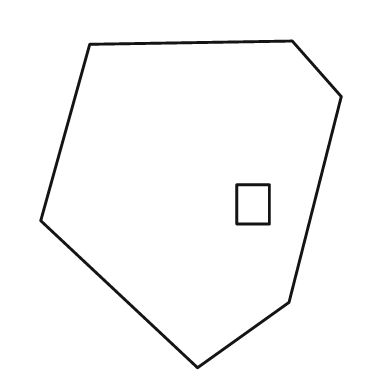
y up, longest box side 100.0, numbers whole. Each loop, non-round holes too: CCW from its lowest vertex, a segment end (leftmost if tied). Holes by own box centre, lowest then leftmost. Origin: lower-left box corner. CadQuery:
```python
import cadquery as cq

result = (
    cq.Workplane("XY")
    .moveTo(48.0, 0.0)
    .lineTo(76.0, 20.0)
    .lineTo(92.0, 83.0)
    .lineTo(77.0, 100.0)
    .lineTo(15.0, 99.0)
    .lineTo(0.0, 45.0)
    .close()
    .moveTo(60.0, 44.0)
    .lineTo(70.0, 44.0)
    .lineTo(70.0, 56.0)
    .lineTo(60.0, 56.0)
    .close()
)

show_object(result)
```